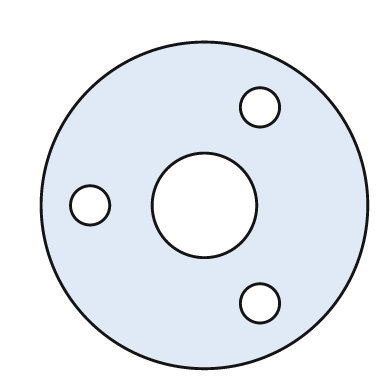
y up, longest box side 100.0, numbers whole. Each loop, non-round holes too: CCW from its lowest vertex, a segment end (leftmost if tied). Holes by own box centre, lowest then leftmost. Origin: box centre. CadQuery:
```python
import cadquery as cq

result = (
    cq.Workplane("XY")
    .moveTo(0.0, 0.0)
    .circle(50.0)
    .moveTo(17.0, -30.0)
    .circle(6.0)
    .moveTo(-35.0, 0.0)
    .circle(6.0)
    .moveTo(0.0, 0.0)
    .circle(16.0)
    .moveTo(17.0, 30.0)
    .circle(6.0)
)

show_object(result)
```